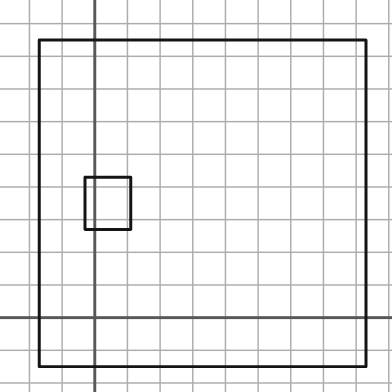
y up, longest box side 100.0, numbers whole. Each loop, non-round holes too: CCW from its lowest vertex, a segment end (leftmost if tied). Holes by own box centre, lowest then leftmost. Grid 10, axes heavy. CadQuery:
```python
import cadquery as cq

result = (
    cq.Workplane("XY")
    .moveTo(-17.0, -15.0)
    .lineTo(83.0, -15.0)
    .lineTo(83.0, 85.0)
    .lineTo(-17.0, 85.0)
    .close()
    .moveTo(-3.0, 27.0)
    .lineTo(11.0, 27.0)
    .lineTo(11.0, 43.0)
    .lineTo(-3.0, 43.0)
    .close()
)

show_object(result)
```